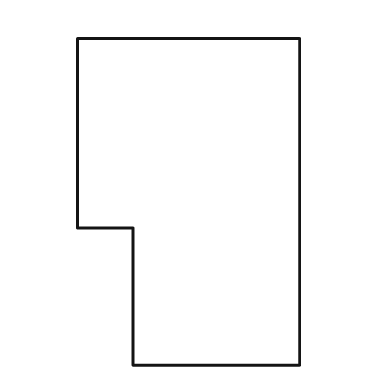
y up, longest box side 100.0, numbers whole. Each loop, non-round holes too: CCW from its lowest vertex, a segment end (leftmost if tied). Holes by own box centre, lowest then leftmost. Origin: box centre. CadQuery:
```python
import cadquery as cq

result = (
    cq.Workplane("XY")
    .moveTo(-17.0, -50.0)
    .lineTo(34.0, -50.0)
    .lineTo(34.0, 50.0)
    .lineTo(-34.0, 50.0)
    .lineTo(-34.0, -8.0)
    .lineTo(-17.0, -8.0)
    .close()
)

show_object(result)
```